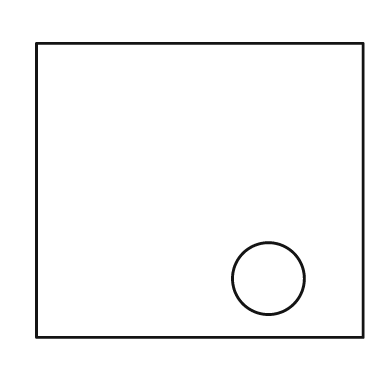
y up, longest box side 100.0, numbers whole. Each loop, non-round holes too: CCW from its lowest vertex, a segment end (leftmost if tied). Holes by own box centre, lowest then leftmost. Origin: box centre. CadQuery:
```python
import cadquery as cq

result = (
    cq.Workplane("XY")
    .moveTo(-50.0, -45.0)
    .lineTo(50.0, -45.0)
    .lineTo(50.0, 45.0)
    .lineTo(-50.0, 45.0)
    .close()
    .moveTo(21.0, -27.0)
    .circle(11.0)
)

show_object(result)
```